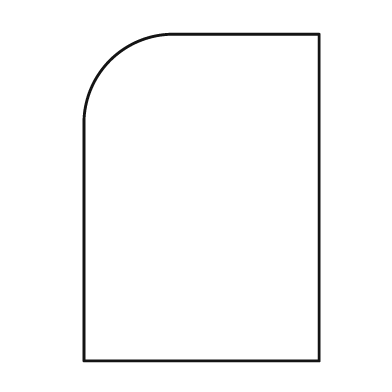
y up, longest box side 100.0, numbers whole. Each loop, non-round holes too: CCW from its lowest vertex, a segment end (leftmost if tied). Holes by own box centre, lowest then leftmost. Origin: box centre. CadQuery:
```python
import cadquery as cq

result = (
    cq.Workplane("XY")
    .moveTo(-36.0, -50.0)
    .lineTo(36.0, -50.0)
    .lineTo(36.0, 50.0)
    .lineTo(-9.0, 50.0)
    .threePointArc((-28.0, 42.0), (-36.0, 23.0))
    .close()
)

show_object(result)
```